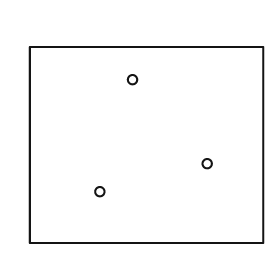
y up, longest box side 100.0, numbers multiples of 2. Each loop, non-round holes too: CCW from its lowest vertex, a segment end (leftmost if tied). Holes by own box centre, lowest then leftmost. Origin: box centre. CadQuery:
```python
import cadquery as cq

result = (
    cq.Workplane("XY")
    .moveTo(-50.0, -42.0)
    .lineTo(50.0, -42.0)
    .lineTo(50.0, 42.0)
    .lineTo(-50.0, 42.0)
    .close()
    .moveTo(-20.0, -20.0)
    .circle(2.0)
    .moveTo(26.0, -8.0)
    .circle(2.0)
    .moveTo(-6.0, 28.0)
    .circle(2.0)
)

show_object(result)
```